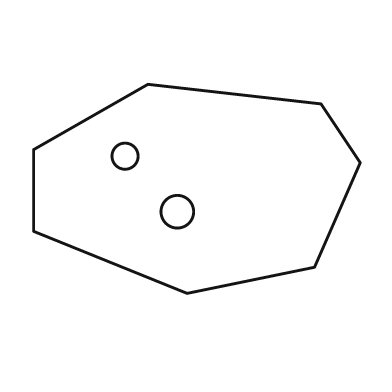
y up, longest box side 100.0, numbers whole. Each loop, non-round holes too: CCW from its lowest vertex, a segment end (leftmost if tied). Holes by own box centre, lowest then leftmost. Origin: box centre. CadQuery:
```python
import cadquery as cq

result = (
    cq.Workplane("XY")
    .moveTo(-3.0, -32.0)
    .lineTo(36.0, -24.0)
    .lineTo(50.0, 8.0)
    .lineTo(38.0, 26.0)
    .lineTo(-15.0, 32.0)
    .lineTo(-50.0, 12.0)
    .lineTo(-50.0, -13.0)
    .close()
    .moveTo(-6.0, -7.0)
    .circle(5.0)
    .moveTo(-22.0, 10.0)
    .circle(4.0)
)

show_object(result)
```